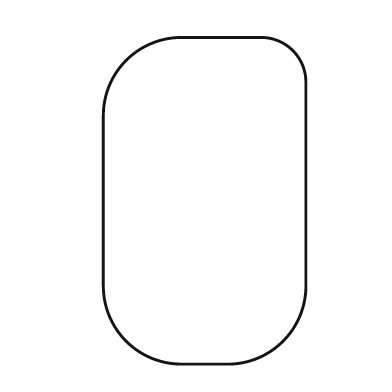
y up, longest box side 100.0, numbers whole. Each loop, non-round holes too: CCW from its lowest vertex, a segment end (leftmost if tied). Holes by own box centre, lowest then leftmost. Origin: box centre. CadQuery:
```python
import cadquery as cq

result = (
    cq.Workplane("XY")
    .moveTo(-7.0, -50.0)
    .lineTo(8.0, -50.0)
    .threePointArc((24.0, -43.0), (31.0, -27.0))
    .lineTo(31.0, 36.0)
    .threePointArc((27.0, 46.0), (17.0, 50.0))
    .lineTo(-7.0, 50.0)
    .threePointArc((-24.0, 43.0), (-31.0, 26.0))
    .lineTo(-31.0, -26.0)
    .threePointArc((-24.0, -43.0), (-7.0, -50.0))
    .close()
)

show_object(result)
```